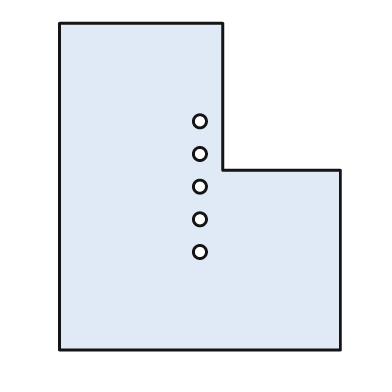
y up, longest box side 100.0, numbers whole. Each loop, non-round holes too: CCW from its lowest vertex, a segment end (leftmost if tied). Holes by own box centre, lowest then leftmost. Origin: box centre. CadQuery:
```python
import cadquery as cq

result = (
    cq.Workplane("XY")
    .moveTo(-43.0, -50.0)
    .lineTo(43.0, -50.0)
    .lineTo(43.0, 5.0)
    .lineTo(7.0, 5.0)
    .lineTo(7.0, 50.0)
    .lineTo(-43.0, 50.0)
    .close()
    .moveTo(0.0, -20.0)
    .circle(2.0)
    .moveTo(0.0, -10.0)
    .circle(2.0)
    .moveTo(0.0, 0.0)
    .circle(2.0)
    .moveTo(0.0, 10.0)
    .circle(2.0)
    .moveTo(0.0, 20.0)
    .circle(2.0)
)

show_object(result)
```